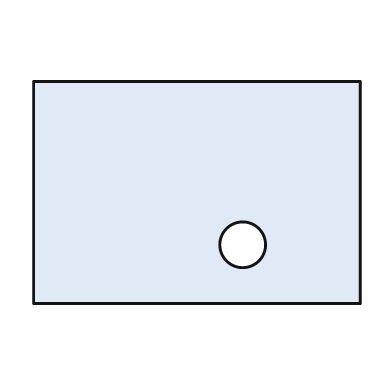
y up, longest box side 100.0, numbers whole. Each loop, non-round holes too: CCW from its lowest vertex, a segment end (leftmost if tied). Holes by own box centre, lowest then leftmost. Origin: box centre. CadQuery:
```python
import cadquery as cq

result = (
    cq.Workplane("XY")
    .moveTo(-50.0, -34.0)
    .lineTo(50.0, -34.0)
    .lineTo(50.0, 34.0)
    .lineTo(-50.0, 34.0)
    .close()
    .moveTo(14.0, -16.0)
    .circle(7.0)
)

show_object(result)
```